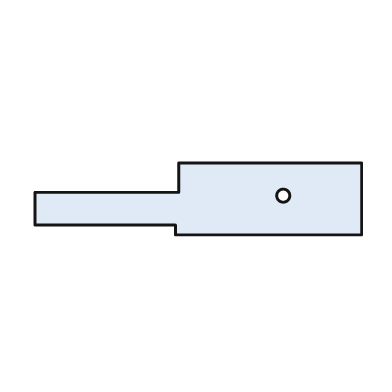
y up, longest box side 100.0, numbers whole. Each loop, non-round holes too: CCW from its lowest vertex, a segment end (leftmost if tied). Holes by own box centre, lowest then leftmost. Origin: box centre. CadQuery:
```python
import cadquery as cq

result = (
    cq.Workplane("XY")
    .moveTo(-7.0, -11.0)
    .lineTo(50.0, -11.0)
    .lineTo(50.0, 11.0)
    .lineTo(-6.0, 11.0)
    .lineTo(-6.0, 2.0)
    .lineTo(-50.0, 2.0)
    .lineTo(-50.0, -8.0)
    .lineTo(-7.0, -8.0)
    .close()
    .moveTo(26.0, 1.0)
    .circle(2.0)
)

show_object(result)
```